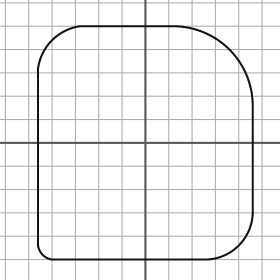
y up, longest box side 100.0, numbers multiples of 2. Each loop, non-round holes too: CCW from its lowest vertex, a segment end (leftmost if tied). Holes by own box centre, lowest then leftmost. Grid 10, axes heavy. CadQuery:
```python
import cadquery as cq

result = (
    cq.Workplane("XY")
    .moveTo(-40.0, -50.0)
    .lineTo(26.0, -50.0)
    .threePointArc((40.0, -44.0), (46.0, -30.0))
    .lineTo(46.0, 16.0)
    .threePointArc((36.0, 40.0), (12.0, 50.0))
    .lineTo(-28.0, 50.0)
    .threePointArc((-40.0, 44.0), (-46.0, 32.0))
    .lineTo(-46.0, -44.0)
    .threePointArc((-44.0, -48.0), (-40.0, -50.0))
    .close()
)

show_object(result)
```